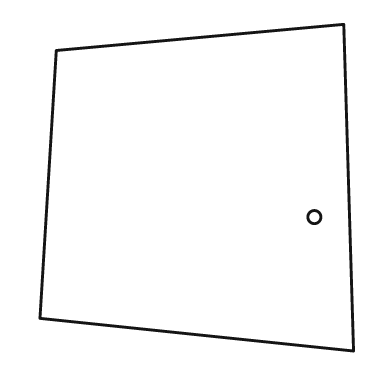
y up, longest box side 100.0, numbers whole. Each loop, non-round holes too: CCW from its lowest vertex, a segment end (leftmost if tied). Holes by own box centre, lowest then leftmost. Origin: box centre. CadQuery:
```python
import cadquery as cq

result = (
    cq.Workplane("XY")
    .moveTo(48.0, -50.0)
    .lineTo(45.0, 50.0)
    .lineTo(-43.0, 42.0)
    .lineTo(-48.0, -40.0)
    .close()
    .moveTo(36.0, -9.0)
    .circle(2.0)
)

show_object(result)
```